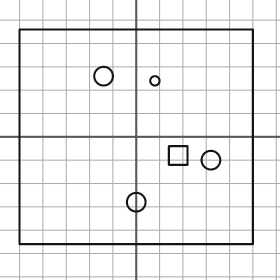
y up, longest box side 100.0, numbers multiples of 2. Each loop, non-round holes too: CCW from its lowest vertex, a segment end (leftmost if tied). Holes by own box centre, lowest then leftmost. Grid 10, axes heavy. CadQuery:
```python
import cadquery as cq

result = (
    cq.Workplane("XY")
    .moveTo(-50.0, -46.0)
    .lineTo(50.0, -46.0)
    .lineTo(50.0, 46.0)
    .lineTo(-50.0, 46.0)
    .close()
    .moveTo(0.0, -28.0)
    .circle(4.0)
    .moveTo(32.0, -10.0)
    .circle(4.0)
    .moveTo(14.0, -12.0)
    .lineTo(22.0, -12.0)
    .lineTo(22.0, -4.0)
    .lineTo(14.0, -4.0)
    .close()
    .moveTo(8.0, 24.0)
    .circle(2.0)
    .moveTo(-14.0, 26.0)
    .circle(4.0)
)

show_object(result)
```